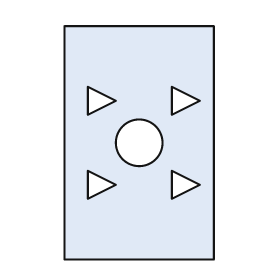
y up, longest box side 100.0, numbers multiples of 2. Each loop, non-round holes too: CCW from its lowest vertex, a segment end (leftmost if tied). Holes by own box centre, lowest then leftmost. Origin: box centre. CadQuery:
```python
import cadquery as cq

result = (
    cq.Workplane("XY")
    .moveTo(-32.0, -50.0)
    .lineTo(32.0, -50.0)
    .lineTo(32.0, 50.0)
    .lineTo(-32.0, 50.0)
    .close()
    .moveTo(-22.0, -24.0)
    .lineTo(-10.0, -18.0)
    .lineTo(-22.0, -12.0)
    .close()
    .moveTo(14.0, -24.0)
    .lineTo(26.0, -18.0)
    .lineTo(14.0, -12.0)
    .close()
    .moveTo(0.0, 0.0)
    .circle(10.0)
    .moveTo(-22.0, 12.0)
    .lineTo(-10.0, 18.0)
    .lineTo(-22.0, 24.0)
    .close()
    .moveTo(14.0, 12.0)
    .lineTo(26.0, 18.0)
    .lineTo(14.0, 24.0)
    .close()
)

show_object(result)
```